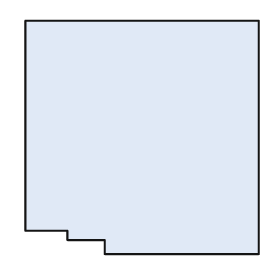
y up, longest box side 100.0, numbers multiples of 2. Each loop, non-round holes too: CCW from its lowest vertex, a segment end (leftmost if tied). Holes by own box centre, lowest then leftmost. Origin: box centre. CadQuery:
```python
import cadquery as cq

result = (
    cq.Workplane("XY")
    .moveTo(-16.0, -50.0)
    .lineTo(50.0, -50.0)
    .lineTo(50.0, 50.0)
    .lineTo(-50.0, 50.0)
    .lineTo(-50.0, -40.0)
    .lineTo(-32.0, -40.0)
    .lineTo(-32.0, -44.0)
    .lineTo(-16.0, -44.0)
    .close()
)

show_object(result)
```